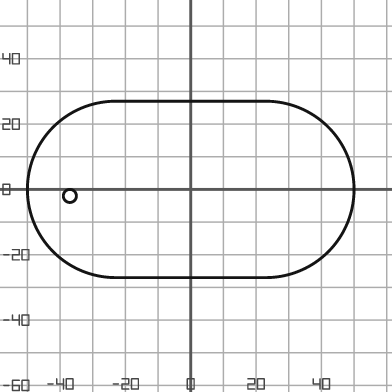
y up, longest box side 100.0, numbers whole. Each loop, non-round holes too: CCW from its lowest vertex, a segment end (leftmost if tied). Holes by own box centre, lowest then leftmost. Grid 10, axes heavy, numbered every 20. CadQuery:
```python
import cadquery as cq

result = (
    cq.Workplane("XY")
    .moveTo(-23.0, -27.0)
    .lineTo(23.0, -27.0)
    .threePointArc((50.0, 0.0), (23.0, 27.0))
    .lineTo(-23.0, 27.0)
    .threePointArc((-50.0, 0.0), (-23.0, -27.0))
    .close()
    .moveTo(-37.0, -2.0)
    .circle(2.0)
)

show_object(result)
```